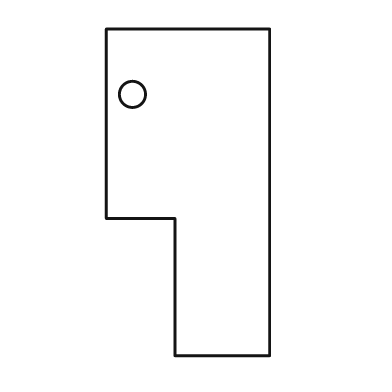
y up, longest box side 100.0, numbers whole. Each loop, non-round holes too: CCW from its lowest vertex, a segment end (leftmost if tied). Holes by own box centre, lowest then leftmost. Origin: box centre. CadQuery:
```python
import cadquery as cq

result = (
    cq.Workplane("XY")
    .moveTo(-4.0, -50.0)
    .lineTo(25.0, -50.0)
    .lineTo(25.0, 50.0)
    .lineTo(-25.0, 50.0)
    .lineTo(-25.0, -8.0)
    .lineTo(-4.0, -8.0)
    .close()
    .moveTo(-17.0, 30.0)
    .circle(4.0)
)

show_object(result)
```